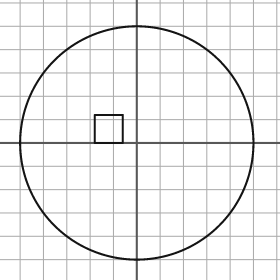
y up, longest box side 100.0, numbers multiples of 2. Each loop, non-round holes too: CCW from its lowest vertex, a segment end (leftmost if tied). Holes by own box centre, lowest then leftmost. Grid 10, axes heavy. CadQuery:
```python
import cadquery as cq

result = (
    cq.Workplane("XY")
    .moveTo(0.0, 0.0)
    .circle(50.0)
    .moveTo(-18.0, 0.0)
    .lineTo(-6.0, 0.0)
    .lineTo(-6.0, 12.0)
    .lineTo(-18.0, 12.0)
    .close()
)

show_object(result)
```